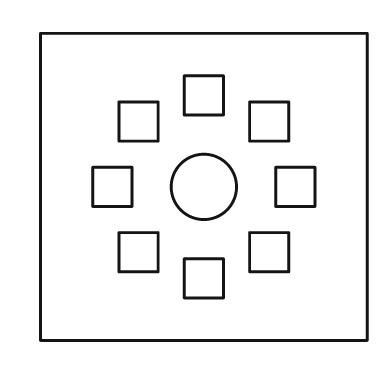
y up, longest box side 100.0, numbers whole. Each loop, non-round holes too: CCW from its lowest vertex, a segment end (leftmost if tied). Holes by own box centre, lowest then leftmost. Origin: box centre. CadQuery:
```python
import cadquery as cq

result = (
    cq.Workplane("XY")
    .moveTo(-50.0, -47.0)
    .lineTo(50.0, -47.0)
    .lineTo(50.0, 47.0)
    .lineTo(-50.0, 47.0)
    .close()
    .moveTo(-6.0, -34.0)
    .lineTo(6.0, -34.0)
    .lineTo(6.0, -22.0)
    .lineTo(-6.0, -22.0)
    .close()
    .moveTo(-26.0, -26.0)
    .lineTo(-14.0, -26.0)
    .lineTo(-14.0, -14.0)
    .lineTo(-26.0, -14.0)
    .close()
    .moveTo(14.0, -26.0)
    .lineTo(26.0, -26.0)
    .lineTo(26.0, -14.0)
    .lineTo(14.0, -14.0)
    .close()
    .moveTo(-34.0, -6.0)
    .lineTo(-22.0, -6.0)
    .lineTo(-22.0, 6.0)
    .lineTo(-34.0, 6.0)
    .close()
    .moveTo(0.0, 0.0)
    .circle(10.0)
    .moveTo(22.0, -6.0)
    .lineTo(34.0, -6.0)
    .lineTo(34.0, 6.0)
    .lineTo(22.0, 6.0)
    .close()
    .moveTo(-26.0, 14.0)
    .lineTo(-14.0, 14.0)
    .lineTo(-14.0, 26.0)
    .lineTo(-26.0, 26.0)
    .close()
    .moveTo(14.0, 14.0)
    .lineTo(26.0, 14.0)
    .lineTo(26.0, 26.0)
    .lineTo(14.0, 26.0)
    .close()
    .moveTo(-6.0, 22.0)
    .lineTo(6.0, 22.0)
    .lineTo(6.0, 34.0)
    .lineTo(-6.0, 34.0)
    .close()
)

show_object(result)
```